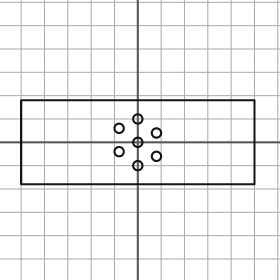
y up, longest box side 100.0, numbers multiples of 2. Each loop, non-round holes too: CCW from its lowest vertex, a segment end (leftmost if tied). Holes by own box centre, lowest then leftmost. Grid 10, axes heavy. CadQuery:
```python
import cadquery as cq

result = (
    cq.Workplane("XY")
    .moveTo(-50.0, -18.0)
    .lineTo(50.0, -18.0)
    .lineTo(50.0, 18.0)
    .lineTo(-50.0, 18.0)
    .close()
    .moveTo(0.0, -10.0)
    .circle(2.0)
    .moveTo(8.0, -6.0)
    .circle(2.0)
    .moveTo(-8.0, -4.0)
    .circle(2.0)
    .moveTo(0.0, 0.0)
    .circle(2.0)
    .moveTo(8.0, 4.0)
    .circle(2.0)
    .moveTo(-8.0, 6.0)
    .circle(2.0)
    .moveTo(0.0, 10.0)
    .circle(2.0)
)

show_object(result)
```